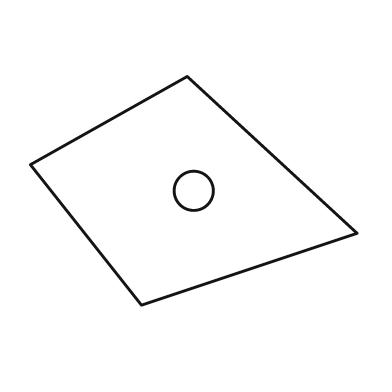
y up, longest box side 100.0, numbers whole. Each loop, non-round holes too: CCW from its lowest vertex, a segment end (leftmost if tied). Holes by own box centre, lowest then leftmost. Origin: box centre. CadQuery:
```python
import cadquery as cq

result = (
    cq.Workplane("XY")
    .moveTo(-16.0, -35.0)
    .lineTo(50.0, -13.0)
    .lineTo(-2.0, 35.0)
    .lineTo(-50.0, 8.0)
    .close()
    .moveTo(0.0, 0.0)
    .circle(6.0)
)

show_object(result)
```